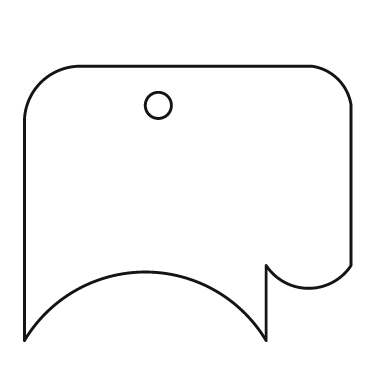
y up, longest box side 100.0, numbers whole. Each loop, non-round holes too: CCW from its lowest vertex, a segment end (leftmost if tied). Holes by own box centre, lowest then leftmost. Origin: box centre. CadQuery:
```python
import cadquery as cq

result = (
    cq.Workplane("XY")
    .moveTo(-50.0, -42.0)
    .threePointArc((-13.0, -21.0), (24.0, -42.0))
    .lineTo(24.0, -19.0)
    .threePointArc((37.0, -26.0), (50.0, -19.0))
    .lineTo(50.0, 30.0)
    .threePointArc((46.0, 38.0), (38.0, 42.0))
    .lineTo(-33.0, 42.0)
    .threePointArc((-45.0, 37.0), (-50.0, 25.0))
    .close()
    .moveTo(-9.0, 30.0)
    .circle(4.0)
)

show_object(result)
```